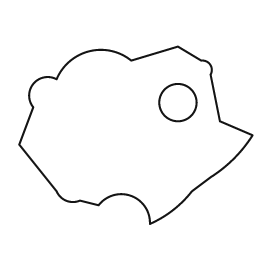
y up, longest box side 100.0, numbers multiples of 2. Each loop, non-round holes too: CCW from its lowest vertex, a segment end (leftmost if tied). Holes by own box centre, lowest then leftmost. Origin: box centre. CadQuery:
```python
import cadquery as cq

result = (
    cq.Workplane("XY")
    .moveTo(6.0, -38.0)
    .threePointArc((16.0, -32.0), (24.0, -24.0))
    .lineTo(32.0, -18.0)
    .threePointArc((42.0, -10.0), (50.0, 0.0))
    .lineTo(36.0, 6.0)
    .lineTo(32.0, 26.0)
    .threePointArc((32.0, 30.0), (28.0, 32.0))
    .lineTo(18.0, 38.0)
    .lineTo(-2.0, 32.0)
    .threePointArc((-20.0, 36.0), (-34.0, 24.0))
    .threePointArc((-44.0, 22.0), (-44.0, 12.0))
    .lineTo(-50.0, -4.0)
    .lineTo(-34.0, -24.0)
    .threePointArc((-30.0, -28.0), (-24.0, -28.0))
    .lineTo(-16.0, -30.0)
    .threePointArc((-2.0, -26.0), (6.0, -38.0))
    .close()
    .moveTo(18.0, 14.0)
    .circle(8.0)
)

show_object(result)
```